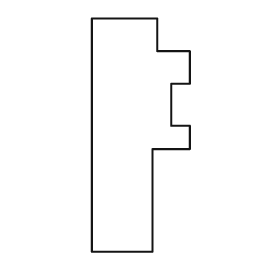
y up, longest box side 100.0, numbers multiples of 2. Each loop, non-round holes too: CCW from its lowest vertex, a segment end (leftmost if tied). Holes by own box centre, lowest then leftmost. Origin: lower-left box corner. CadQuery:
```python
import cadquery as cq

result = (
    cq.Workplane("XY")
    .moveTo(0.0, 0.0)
    .lineTo(26.0, 0.0)
    .lineTo(26.0, 44.0)
    .lineTo(42.0, 44.0)
    .lineTo(42.0, 54.0)
    .lineTo(34.0, 54.0)
    .lineTo(34.0, 72.0)
    .lineTo(42.0, 72.0)
    .lineTo(42.0, 86.0)
    .lineTo(28.0, 86.0)
    .lineTo(28.0, 100.0)
    .lineTo(0.0, 100.0)
    .close()
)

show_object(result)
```